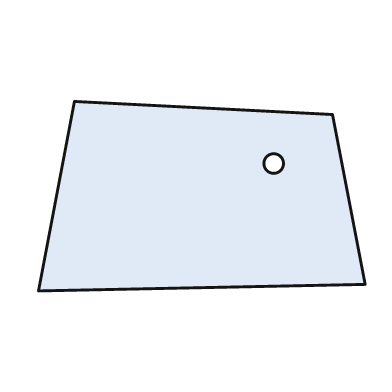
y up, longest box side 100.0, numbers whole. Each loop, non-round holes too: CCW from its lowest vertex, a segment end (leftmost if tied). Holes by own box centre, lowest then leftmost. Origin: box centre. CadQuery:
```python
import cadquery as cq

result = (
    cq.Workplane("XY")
    .moveTo(-50.0, -29.0)
    .lineTo(50.0, -27.0)
    .lineTo(40.0, 25.0)
    .lineTo(-39.0, 29.0)
    .close()
    .moveTo(22.0, 10.0)
    .circle(3.0)
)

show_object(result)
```